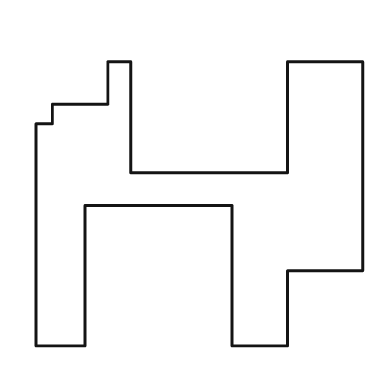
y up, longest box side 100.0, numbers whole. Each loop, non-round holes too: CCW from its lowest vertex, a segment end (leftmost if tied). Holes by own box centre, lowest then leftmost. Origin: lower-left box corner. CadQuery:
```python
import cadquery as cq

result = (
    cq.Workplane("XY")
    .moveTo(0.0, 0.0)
    .lineTo(15.0, 0.0)
    .lineTo(15.0, 43.0)
    .lineTo(60.0, 43.0)
    .lineTo(60.0, 0.0)
    .lineTo(77.0, 0.0)
    .lineTo(77.0, 23.0)
    .lineTo(100.0, 23.0)
    .lineTo(100.0, 87.0)
    .lineTo(77.0, 87.0)
    .lineTo(77.0, 53.0)
    .lineTo(29.0, 53.0)
    .lineTo(29.0, 87.0)
    .lineTo(22.0, 87.0)
    .lineTo(22.0, 74.0)
    .lineTo(5.0, 74.0)
    .lineTo(5.0, 68.0)
    .lineTo(0.0, 68.0)
    .close()
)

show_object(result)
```